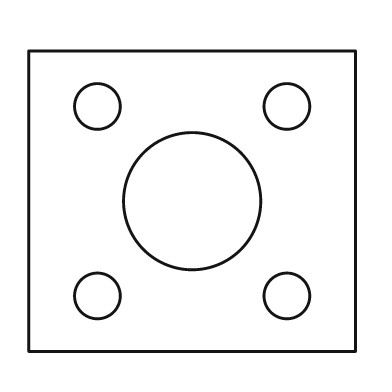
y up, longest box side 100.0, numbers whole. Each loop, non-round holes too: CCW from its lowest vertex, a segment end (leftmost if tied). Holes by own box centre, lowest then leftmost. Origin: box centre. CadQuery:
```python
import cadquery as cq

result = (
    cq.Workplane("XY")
    .moveTo(-50.0, -46.0)
    .lineTo(50.0, -46.0)
    .lineTo(50.0, 46.0)
    .lineTo(-50.0, 46.0)
    .close()
    .moveTo(-29.0, -29.0)
    .circle(7.0)
    .moveTo(29.0, -29.0)
    .circle(7.0)
    .moveTo(0.0, 0.0)
    .circle(21.0)
    .moveTo(-29.0, 29.0)
    .circle(7.0)
    .moveTo(29.0, 29.0)
    .circle(7.0)
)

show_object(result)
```